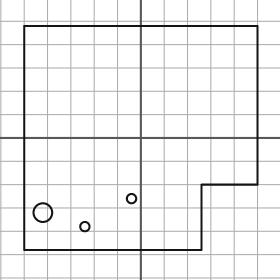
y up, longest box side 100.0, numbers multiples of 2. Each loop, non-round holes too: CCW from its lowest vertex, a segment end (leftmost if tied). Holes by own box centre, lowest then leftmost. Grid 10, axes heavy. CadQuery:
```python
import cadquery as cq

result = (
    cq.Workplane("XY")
    .moveTo(-50.0, -48.0)
    .lineTo(26.0, -48.0)
    .lineTo(26.0, -20.0)
    .lineTo(50.0, -20.0)
    .lineTo(50.0, 48.0)
    .lineTo(-50.0, 48.0)
    .close()
    .moveTo(-24.0, -38.0)
    .circle(2.0)
    .moveTo(-42.0, -32.0)
    .circle(4.0)
    .moveTo(-4.0, -26.0)
    .circle(2.0)
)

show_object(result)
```